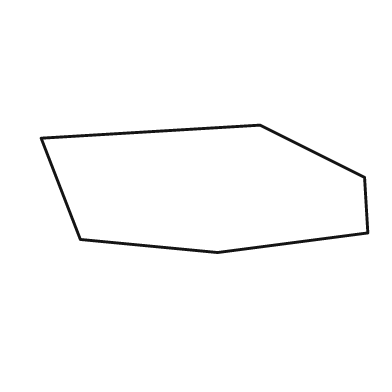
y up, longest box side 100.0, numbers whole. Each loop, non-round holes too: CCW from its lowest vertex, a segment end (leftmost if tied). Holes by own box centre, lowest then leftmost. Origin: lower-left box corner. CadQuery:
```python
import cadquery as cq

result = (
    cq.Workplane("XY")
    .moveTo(54.0, 0.0)
    .lineTo(100.0, 6.0)
    .lineTo(99.0, 23.0)
    .lineTo(67.0, 39.0)
    .lineTo(0.0, 35.0)
    .lineTo(12.0, 4.0)
    .close()
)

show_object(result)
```